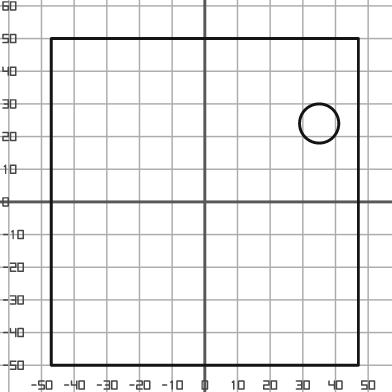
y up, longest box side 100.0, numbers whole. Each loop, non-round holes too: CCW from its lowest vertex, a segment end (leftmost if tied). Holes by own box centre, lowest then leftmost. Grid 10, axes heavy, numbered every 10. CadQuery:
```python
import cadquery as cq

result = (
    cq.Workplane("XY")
    .moveTo(-47.0, -50.0)
    .lineTo(47.0, -50.0)
    .lineTo(47.0, 50.0)
    .lineTo(-47.0, 50.0)
    .close()
    .moveTo(35.0, 24.0)
    .circle(6.0)
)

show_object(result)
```